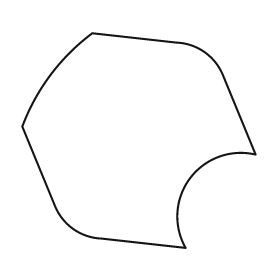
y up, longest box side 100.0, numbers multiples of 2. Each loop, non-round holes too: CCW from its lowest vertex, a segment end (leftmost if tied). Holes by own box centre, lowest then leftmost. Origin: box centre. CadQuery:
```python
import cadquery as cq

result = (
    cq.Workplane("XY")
    .moveTo(20.0, -46.0)
    .threePointArc((22.0, -16.0), (50.0, -6.0))
    .lineTo(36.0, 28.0)
    .threePointArc((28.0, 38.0), (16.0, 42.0))
    .lineTo(-20.0, 46.0)
    .threePointArc((-38.0, 28.0), (-50.0, 6.0))
    .lineTo(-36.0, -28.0)
    .threePointArc((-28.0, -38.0), (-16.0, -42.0))
    .close()
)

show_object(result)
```